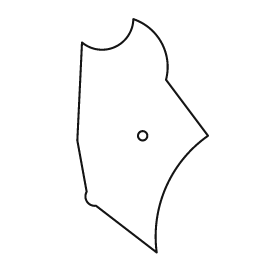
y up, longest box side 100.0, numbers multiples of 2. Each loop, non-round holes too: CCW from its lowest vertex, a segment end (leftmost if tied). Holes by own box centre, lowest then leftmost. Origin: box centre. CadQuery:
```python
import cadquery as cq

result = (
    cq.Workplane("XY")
    .moveTo(6.0, -50.0)
    .threePointArc((10.0, -22.0), (28.0, 0.0))
    .lineTo(10.0, 24.0)
    .threePointArc((8.0, 40.0), (-4.0, 50.0))
    .threePointArc((-12.0, 38.0), (-26.0, 40.0))
    .lineTo(-28.0, -2.0)
    .lineTo(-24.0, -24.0)
    .threePointArc((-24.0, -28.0), (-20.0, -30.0))
    .close()
    .moveTo(0.0, 0.0)
    .circle(2.0)
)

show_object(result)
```